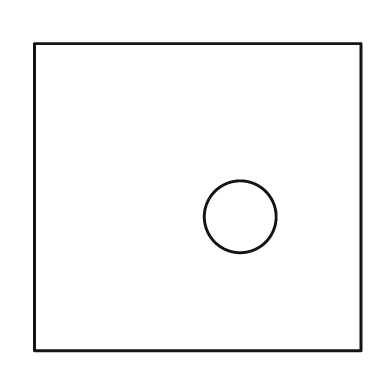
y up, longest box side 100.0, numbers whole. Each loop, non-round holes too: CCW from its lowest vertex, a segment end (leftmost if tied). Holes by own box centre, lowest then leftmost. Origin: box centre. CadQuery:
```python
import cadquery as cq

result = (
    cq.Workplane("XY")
    .moveTo(-50.0, -47.0)
    .lineTo(50.0, -47.0)
    .lineTo(50.0, 47.0)
    .lineTo(-50.0, 47.0)
    .close()
    .moveTo(13.0, -6.0)
    .circle(11.0)
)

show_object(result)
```